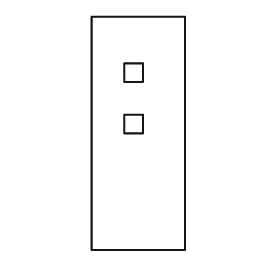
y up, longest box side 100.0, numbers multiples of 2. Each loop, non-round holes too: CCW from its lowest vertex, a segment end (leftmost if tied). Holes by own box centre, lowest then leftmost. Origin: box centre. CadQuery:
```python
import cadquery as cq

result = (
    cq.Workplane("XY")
    .moveTo(-20.0, -50.0)
    .lineTo(20.0, -50.0)
    .lineTo(20.0, 50.0)
    .lineTo(-20.0, 50.0)
    .close()
    .moveTo(-6.0, 0.0)
    .lineTo(2.0, 0.0)
    .lineTo(2.0, 8.0)
    .lineTo(-6.0, 8.0)
    .close()
    .moveTo(-6.0, 22.0)
    .lineTo(2.0, 22.0)
    .lineTo(2.0, 30.0)
    .lineTo(-6.0, 30.0)
    .close()
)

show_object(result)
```